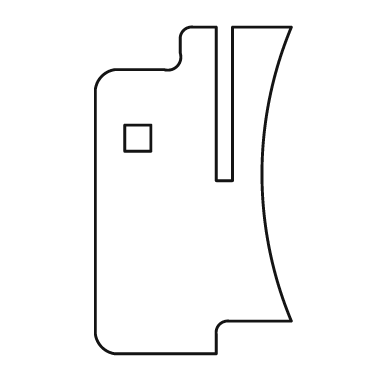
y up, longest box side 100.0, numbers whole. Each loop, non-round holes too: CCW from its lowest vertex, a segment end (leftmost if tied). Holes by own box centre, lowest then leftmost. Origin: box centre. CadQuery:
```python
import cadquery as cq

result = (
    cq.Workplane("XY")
    .moveTo(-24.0, -50.0)
    .lineTo(7.0, -50.0)
    .lineTo(7.0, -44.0)
    .threePointArc((8.0, -41.0), (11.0, -40.0))
    .lineTo(30.0, -40.0)
    .threePointArc((21.0, 5.0), (30.0, 50.0))
    .lineTo(12.0, 50.0)
    .lineTo(12.0, 3.0)
    .lineTo(7.0, 3.0)
    .lineTo(7.0, 50.0)
    .lineTo(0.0, 50.0)
    .threePointArc((-3.0, 49.0), (-4.0, 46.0))
    .lineTo(-4.0, 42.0)
    .threePointArc((-5.0, 38.0), (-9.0, 37.0))
    .lineTo(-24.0, 37.0)
    .threePointArc((-28.0, 35.0), (-30.0, 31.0))
    .lineTo(-30.0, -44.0)
    .threePointArc((-28.0, -48.0), (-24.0, -50.0))
    .close()
    .moveTo(-21.0, 12.0)
    .lineTo(-13.0, 12.0)
    .lineTo(-13.0, 20.0)
    .lineTo(-21.0, 20.0)
    .close()
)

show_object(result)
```